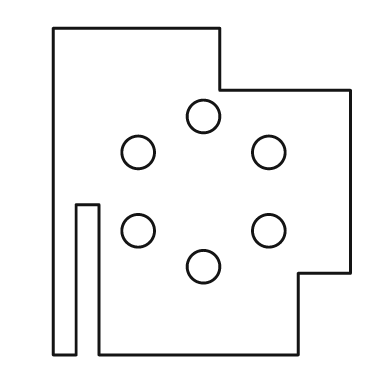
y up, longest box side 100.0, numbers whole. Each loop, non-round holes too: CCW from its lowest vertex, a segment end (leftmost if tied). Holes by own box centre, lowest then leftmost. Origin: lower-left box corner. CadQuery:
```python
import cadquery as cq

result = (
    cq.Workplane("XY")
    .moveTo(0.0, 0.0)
    .lineTo(7.0, 0.0)
    .lineTo(7.0, 46.0)
    .lineTo(14.0, 46.0)
    .lineTo(14.0, 0.0)
    .lineTo(75.0, 0.0)
    .lineTo(75.0, 25.0)
    .lineTo(91.0, 25.0)
    .lineTo(91.0, 81.0)
    .lineTo(51.0, 81.0)
    .lineTo(51.0, 100.0)
    .lineTo(0.0, 100.0)
    .close()
    .moveTo(46.0, 27.0)
    .circle(5.0)
    .moveTo(26.0, 38.0)
    .circle(5.0)
    .moveTo(66.0, 38.0)
    .circle(5.0)
    .moveTo(26.0, 62.0)
    .circle(5.0)
    .moveTo(66.0, 62.0)
    .circle(5.0)
    .moveTo(46.0, 73.0)
    .circle(5.0)
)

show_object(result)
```